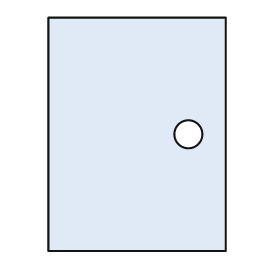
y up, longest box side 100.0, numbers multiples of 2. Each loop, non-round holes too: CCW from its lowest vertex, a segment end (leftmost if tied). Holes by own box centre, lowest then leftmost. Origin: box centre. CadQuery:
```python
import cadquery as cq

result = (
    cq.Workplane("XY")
    .moveTo(-38.0, -50.0)
    .lineTo(38.0, -50.0)
    .lineTo(38.0, 50.0)
    .lineTo(-38.0, 50.0)
    .close()
    .moveTo(22.0, 0.0)
    .circle(6.0)
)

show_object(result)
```